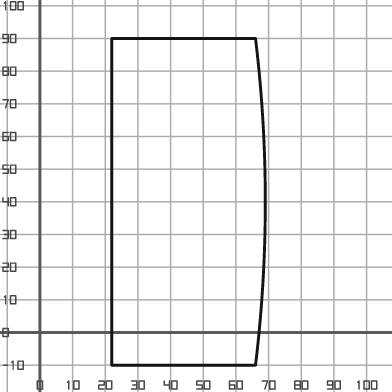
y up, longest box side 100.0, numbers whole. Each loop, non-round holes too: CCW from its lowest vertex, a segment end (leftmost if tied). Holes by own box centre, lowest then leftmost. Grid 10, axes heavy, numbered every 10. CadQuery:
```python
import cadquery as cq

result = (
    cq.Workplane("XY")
    .moveTo(22.0, -10.0)
    .lineTo(66.0, -10.0)
    .threePointArc((69.0, 40.0), (66.0, 90.0))
    .lineTo(22.0, 90.0)
    .close()
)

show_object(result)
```